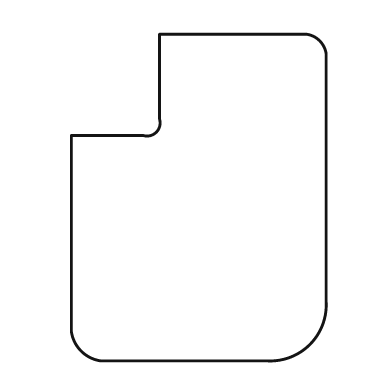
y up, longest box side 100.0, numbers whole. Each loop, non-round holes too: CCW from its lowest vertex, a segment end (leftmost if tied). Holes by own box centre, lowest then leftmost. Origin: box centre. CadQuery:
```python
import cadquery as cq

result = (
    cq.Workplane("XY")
    .moveTo(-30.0, -50.0)
    .lineTo(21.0, -50.0)
    .threePointArc((34.0, -45.0), (39.0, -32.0))
    .lineTo(39.0, 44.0)
    .threePointArc((37.0, 48.0), (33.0, 50.0))
    .lineTo(-12.0, 50.0)
    .lineTo(-12.0, 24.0)
    .threePointArc((-13.0, 20.0), (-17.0, 19.0))
    .lineTo(-39.0, 19.0)
    .lineTo(-39.0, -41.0)
    .threePointArc((-36.0, -47.0), (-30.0, -50.0))
    .close()
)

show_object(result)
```